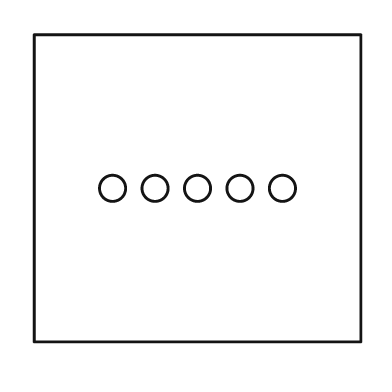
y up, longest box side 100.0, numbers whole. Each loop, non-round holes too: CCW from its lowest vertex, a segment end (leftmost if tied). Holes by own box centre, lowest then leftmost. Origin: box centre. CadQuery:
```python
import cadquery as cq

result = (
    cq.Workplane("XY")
    .moveTo(-50.0, -47.0)
    .lineTo(50.0, -47.0)
    .lineTo(50.0, 47.0)
    .lineTo(-50.0, 47.0)
    .close()
    .moveTo(-26.0, 0.0)
    .circle(4.0)
    .moveTo(-13.0, 0.0)
    .circle(4.0)
    .moveTo(0.0, 0.0)
    .circle(4.0)
    .moveTo(13.0, 0.0)
    .circle(4.0)
    .moveTo(26.0, 0.0)
    .circle(4.0)
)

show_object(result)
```